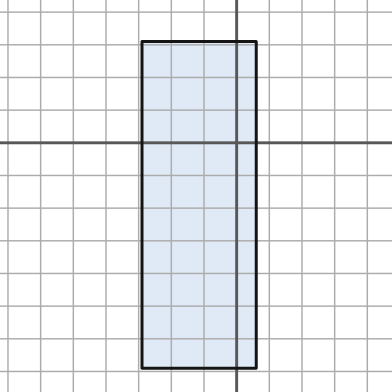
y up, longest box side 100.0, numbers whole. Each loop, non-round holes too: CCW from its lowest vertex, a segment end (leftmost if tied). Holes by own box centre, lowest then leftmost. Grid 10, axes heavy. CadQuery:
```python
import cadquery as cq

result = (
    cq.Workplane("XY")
    .moveTo(-29.0, -69.0)
    .lineTo(6.0, -69.0)
    .lineTo(6.0, 31.0)
    .lineTo(-29.0, 31.0)
    .close()
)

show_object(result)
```